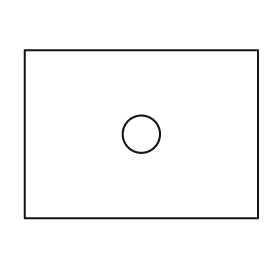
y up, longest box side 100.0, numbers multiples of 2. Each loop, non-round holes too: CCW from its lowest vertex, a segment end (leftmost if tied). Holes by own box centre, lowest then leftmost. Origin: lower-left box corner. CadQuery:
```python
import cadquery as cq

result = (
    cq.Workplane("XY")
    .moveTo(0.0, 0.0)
    .lineTo(100.0, 0.0)
    .lineTo(100.0, 72.0)
    .lineTo(0.0, 72.0)
    .close()
    .moveTo(50.0, 36.0)
    .circle(8.0)
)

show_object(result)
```